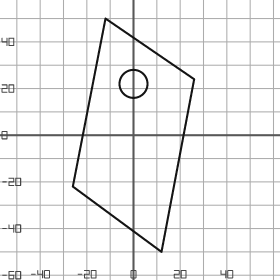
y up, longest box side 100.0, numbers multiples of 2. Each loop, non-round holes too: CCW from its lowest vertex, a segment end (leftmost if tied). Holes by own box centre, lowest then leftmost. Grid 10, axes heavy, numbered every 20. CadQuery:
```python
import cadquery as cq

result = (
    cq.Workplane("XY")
    .moveTo(12.0, -50.0)
    .lineTo(26.0, 24.0)
    .lineTo(-12.0, 50.0)
    .lineTo(-26.0, -22.0)
    .close()
    .moveTo(0.0, 22.0)
    .circle(6.0)
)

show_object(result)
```